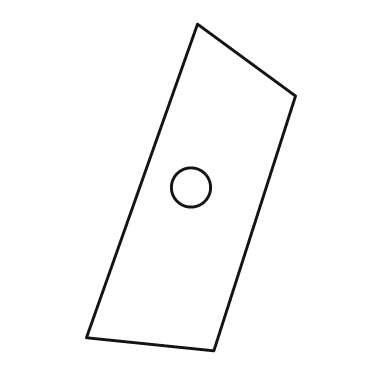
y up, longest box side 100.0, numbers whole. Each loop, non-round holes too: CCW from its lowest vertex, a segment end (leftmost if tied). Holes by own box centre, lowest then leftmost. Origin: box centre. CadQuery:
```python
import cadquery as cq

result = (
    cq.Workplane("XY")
    .moveTo(7.0, -50.0)
    .lineTo(32.0, 28.0)
    .lineTo(2.0, 50.0)
    .lineTo(-32.0, -46.0)
    .close()
    .moveTo(0.0, 0.0)
    .circle(6.0)
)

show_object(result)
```